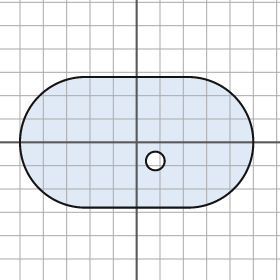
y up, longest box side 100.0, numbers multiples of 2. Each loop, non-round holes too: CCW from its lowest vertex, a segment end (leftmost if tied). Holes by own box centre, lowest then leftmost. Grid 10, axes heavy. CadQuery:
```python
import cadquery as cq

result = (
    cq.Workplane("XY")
    .moveTo(-22.0, -28.0)
    .lineTo(22.0, -28.0)
    .threePointArc((50.0, 0.0), (22.0, 28.0))
    .lineTo(-22.0, 28.0)
    .threePointArc((-50.0, 0.0), (-22.0, -28.0))
    .close()
    .moveTo(8.0, -8.0)
    .circle(4.0)
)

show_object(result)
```